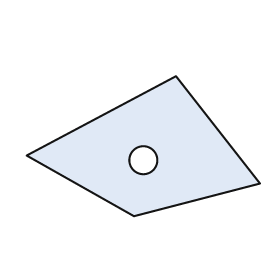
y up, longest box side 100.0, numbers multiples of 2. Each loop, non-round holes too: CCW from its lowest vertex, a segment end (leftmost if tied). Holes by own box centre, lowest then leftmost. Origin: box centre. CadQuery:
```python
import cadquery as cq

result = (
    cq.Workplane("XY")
    .moveTo(-4.0, -30.0)
    .lineTo(50.0, -16.0)
    .lineTo(14.0, 30.0)
    .lineTo(-50.0, -4.0)
    .close()
    .moveTo(0.0, -6.0)
    .circle(6.0)
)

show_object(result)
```